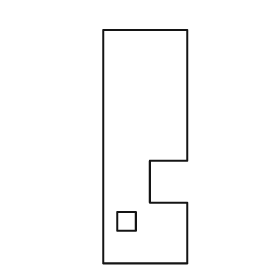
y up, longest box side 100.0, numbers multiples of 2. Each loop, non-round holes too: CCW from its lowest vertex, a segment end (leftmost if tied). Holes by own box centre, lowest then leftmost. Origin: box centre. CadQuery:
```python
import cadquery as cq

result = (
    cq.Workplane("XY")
    .moveTo(-18.0, -50.0)
    .lineTo(18.0, -50.0)
    .lineTo(18.0, -24.0)
    .lineTo(2.0, -24.0)
    .lineTo(2.0, -6.0)
    .lineTo(18.0, -6.0)
    .lineTo(18.0, 50.0)
    .lineTo(-18.0, 50.0)
    .close()
    .moveTo(-12.0, -36.0)
    .lineTo(-4.0, -36.0)
    .lineTo(-4.0, -28.0)
    .lineTo(-12.0, -28.0)
    .close()
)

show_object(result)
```